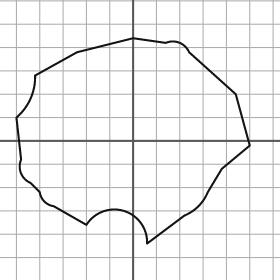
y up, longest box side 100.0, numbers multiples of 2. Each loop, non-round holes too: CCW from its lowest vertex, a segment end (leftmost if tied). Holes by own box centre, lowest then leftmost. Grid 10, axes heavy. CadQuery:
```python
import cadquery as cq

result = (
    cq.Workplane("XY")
    .moveTo(6.0, -44.0)
    .lineTo(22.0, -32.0)
    .threePointArc((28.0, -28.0), (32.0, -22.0))
    .lineTo(38.0, -12.0)
    .lineTo(50.0, -2.0)
    .lineTo(44.0, 20.0)
    .lineTo(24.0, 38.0)
    .threePointArc((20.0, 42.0), (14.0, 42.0))
    .lineTo(0.0, 44.0)
    .lineTo(-24.0, 38.0)
    .lineTo(-42.0, 28.0)
    .threePointArc((-44.0, 18.0), (-50.0, 10.0))
    .lineTo(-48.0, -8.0)
    .threePointArc((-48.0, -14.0), (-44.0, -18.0))
    .lineTo(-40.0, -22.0)
    .threePointArc((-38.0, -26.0), (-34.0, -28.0))
    .lineTo(-20.0, -36.0)
    .threePointArc((-4.0, -30.0), (6.0, -44.0))
    .close()
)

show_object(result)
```